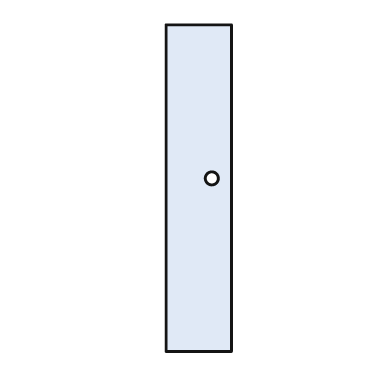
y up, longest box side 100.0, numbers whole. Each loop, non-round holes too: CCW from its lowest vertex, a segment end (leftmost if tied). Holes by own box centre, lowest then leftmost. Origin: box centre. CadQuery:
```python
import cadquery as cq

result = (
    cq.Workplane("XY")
    .moveTo(-10.0, -50.0)
    .lineTo(10.0, -50.0)
    .lineTo(10.0, 50.0)
    .lineTo(-10.0, 50.0)
    .close()
    .moveTo(4.0, 3.0)
    .circle(2.0)
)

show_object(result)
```